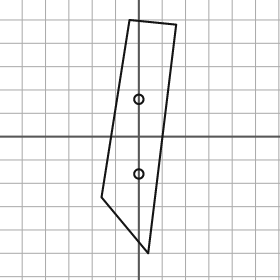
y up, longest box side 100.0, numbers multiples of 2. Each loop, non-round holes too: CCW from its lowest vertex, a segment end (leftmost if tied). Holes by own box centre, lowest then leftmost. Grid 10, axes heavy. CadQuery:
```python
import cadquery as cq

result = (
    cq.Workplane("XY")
    .moveTo(4.0, -50.0)
    .lineTo(16.0, 48.0)
    .lineTo(-4.0, 50.0)
    .lineTo(-16.0, -26.0)
    .close()
    .moveTo(0.0, -16.0)
    .circle(2.0)
    .moveTo(0.0, 16.0)
    .circle(2.0)
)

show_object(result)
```